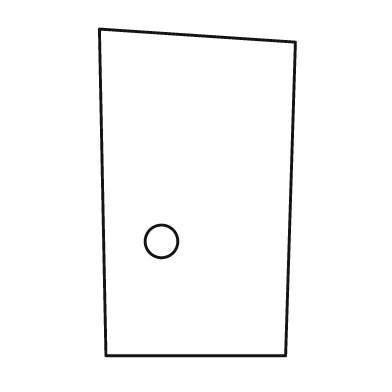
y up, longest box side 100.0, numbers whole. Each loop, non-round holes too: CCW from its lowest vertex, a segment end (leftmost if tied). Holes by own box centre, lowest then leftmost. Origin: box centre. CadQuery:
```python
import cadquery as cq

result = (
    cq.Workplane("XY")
    .moveTo(-28.0, -50.0)
    .lineTo(27.0, -50.0)
    .lineTo(30.0, 46.0)
    .lineTo(-30.0, 50.0)
    .close()
    .moveTo(-11.0, -15.0)
    .circle(5.0)
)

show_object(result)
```